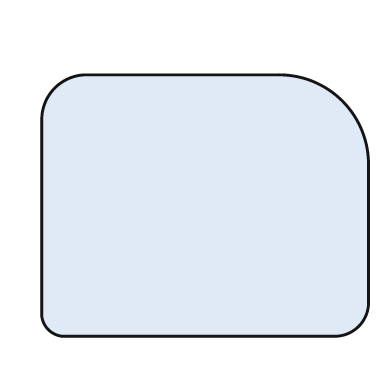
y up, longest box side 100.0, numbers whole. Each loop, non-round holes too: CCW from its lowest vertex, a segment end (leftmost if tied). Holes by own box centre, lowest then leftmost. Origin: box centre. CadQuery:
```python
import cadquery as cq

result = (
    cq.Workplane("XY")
    .moveTo(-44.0, -40.0)
    .lineTo(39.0, -40.0)
    .threePointArc((47.0, -37.0), (50.0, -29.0))
    .lineTo(50.0, 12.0)
    .threePointArc((42.0, 32.0), (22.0, 40.0))
    .lineTo(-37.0, 40.0)
    .threePointArc((-46.0, 36.0), (-50.0, 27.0))
    .lineTo(-50.0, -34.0)
    .threePointArc((-48.0, -38.0), (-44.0, -40.0))
    .close()
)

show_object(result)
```